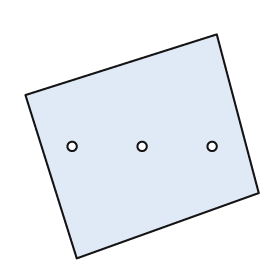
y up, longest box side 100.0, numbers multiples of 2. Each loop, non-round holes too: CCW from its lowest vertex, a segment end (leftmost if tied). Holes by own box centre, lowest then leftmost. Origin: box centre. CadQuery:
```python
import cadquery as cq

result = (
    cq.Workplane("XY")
    .moveTo(-28.0, -48.0)
    .lineTo(50.0, -20.0)
    .lineTo(32.0, 48.0)
    .lineTo(-50.0, 22.0)
    .close()
    .moveTo(-30.0, 0.0)
    .circle(2.0)
    .moveTo(0.0, 0.0)
    .circle(2.0)
    .moveTo(30.0, 0.0)
    .circle(2.0)
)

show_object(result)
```